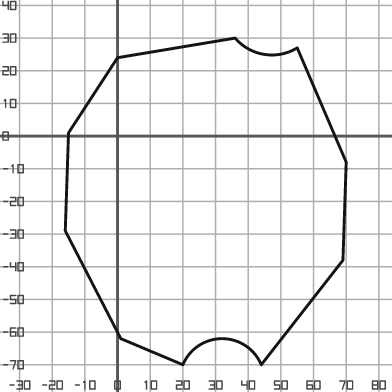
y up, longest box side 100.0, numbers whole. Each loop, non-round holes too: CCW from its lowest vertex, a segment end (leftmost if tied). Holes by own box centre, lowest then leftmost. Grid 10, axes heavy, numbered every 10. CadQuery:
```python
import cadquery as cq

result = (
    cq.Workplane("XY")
    .moveTo(20.0, -70.0)
    .threePointArc((32.0, -62.0), (44.0, -70.0))
    .lineTo(69.0, -38.0)
    .lineTo(70.0, -8.0)
    .lineTo(55.0, 27.0)
    .threePointArc((45.0, 25.0), (36.0, 30.0))
    .lineTo(0.0, 24.0)
    .lineTo(-15.0, 1.0)
    .lineTo(-16.0, -29.0)
    .lineTo(1.0, -62.0)
    .close()
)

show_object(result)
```